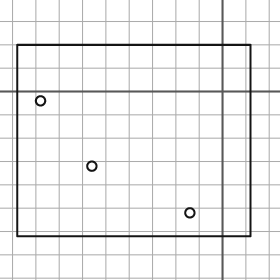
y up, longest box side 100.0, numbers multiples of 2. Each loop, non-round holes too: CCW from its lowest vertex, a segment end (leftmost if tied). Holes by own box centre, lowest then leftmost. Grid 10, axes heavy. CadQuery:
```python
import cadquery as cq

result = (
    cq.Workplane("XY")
    .moveTo(-88.0, -62.0)
    .lineTo(12.0, -62.0)
    .lineTo(12.0, 20.0)
    .lineTo(-88.0, 20.0)
    .close()
    .moveTo(-14.0, -52.0)
    .circle(2.0)
    .moveTo(-56.0, -32.0)
    .circle(2.0)
    .moveTo(-78.0, -4.0)
    .circle(2.0)
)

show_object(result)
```